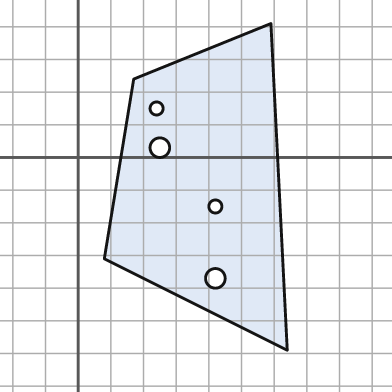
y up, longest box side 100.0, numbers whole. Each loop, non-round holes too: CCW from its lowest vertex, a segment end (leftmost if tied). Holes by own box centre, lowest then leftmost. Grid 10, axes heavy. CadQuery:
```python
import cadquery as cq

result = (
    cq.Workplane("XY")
    .moveTo(64.0, -59.0)
    .lineTo(59.0, 41.0)
    .lineTo(17.0, 24.0)
    .lineTo(8.0, -31.0)
    .close()
    .moveTo(42.0, -37.0)
    .circle(3.0)
    .moveTo(42.0, -15.0)
    .circle(2.0)
    .moveTo(25.0, 3.0)
    .circle(3.0)
    .moveTo(24.0, 15.0)
    .circle(2.0)
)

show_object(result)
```